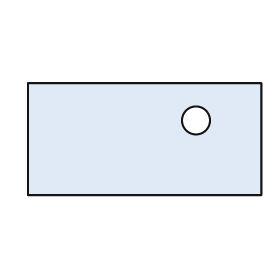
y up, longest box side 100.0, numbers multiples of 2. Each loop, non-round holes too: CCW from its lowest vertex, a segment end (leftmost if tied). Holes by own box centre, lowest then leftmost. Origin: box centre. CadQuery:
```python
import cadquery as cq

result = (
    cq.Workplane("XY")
    .moveTo(-50.0, -24.0)
    .lineTo(50.0, -24.0)
    .lineTo(50.0, 24.0)
    .lineTo(-50.0, 24.0)
    .close()
    .moveTo(22.0, 8.0)
    .circle(6.0)
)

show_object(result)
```